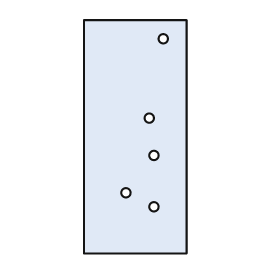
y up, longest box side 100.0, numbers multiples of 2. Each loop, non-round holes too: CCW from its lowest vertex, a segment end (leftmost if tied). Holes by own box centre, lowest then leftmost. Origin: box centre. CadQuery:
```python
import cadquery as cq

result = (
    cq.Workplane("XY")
    .moveTo(-22.0, -50.0)
    .lineTo(22.0, -50.0)
    .lineTo(22.0, 50.0)
    .lineTo(-22.0, 50.0)
    .close()
    .moveTo(8.0, -30.0)
    .circle(2.0)
    .moveTo(-4.0, -24.0)
    .circle(2.0)
    .moveTo(8.0, -8.0)
    .circle(2.0)
    .moveTo(6.0, 8.0)
    .circle(2.0)
    .moveTo(12.0, 42.0)
    .circle(2.0)
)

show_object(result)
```